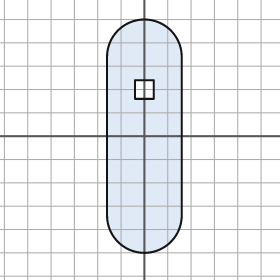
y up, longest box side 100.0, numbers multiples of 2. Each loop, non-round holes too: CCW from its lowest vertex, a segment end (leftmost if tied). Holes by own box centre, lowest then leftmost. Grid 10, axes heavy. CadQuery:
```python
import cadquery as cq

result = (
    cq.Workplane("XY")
    .moveTo(-16.0, -34.0)
    .threePointArc((0.0, -50.0), (16.0, -34.0))
    .lineTo(16.0, 34.0)
    .threePointArc((0.0, 50.0), (-16.0, 34.0))
    .close()
    .moveTo(-4.0, 16.0)
    .lineTo(4.0, 16.0)
    .lineTo(4.0, 24.0)
    .lineTo(-4.0, 24.0)
    .close()
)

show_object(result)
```